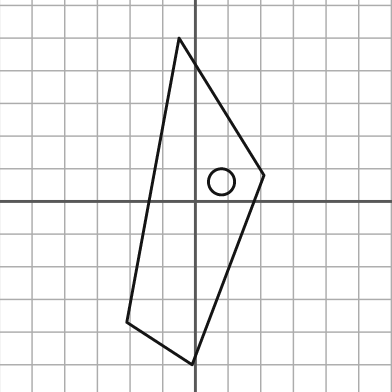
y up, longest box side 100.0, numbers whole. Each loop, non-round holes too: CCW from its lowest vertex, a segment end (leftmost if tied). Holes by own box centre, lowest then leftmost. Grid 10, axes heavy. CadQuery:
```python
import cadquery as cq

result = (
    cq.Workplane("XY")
    .moveTo(-1.0, -50.0)
    .lineTo(21.0, 8.0)
    .lineTo(-5.0, 50.0)
    .lineTo(-21.0, -37.0)
    .close()
    .moveTo(8.0, 6.0)
    .circle(4.0)
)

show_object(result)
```